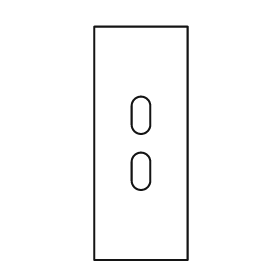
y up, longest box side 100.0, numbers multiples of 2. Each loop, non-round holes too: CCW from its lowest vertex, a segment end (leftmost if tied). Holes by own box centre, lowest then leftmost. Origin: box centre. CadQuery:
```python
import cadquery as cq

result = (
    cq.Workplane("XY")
    .moveTo(-20.0, -50.0)
    .lineTo(20.0, -50.0)
    .lineTo(20.0, 50.0)
    .lineTo(-20.0, 50.0)
    .close()
    .moveTo(-4.0, -16.0)
    .threePointArc((0.0, -20.0), (4.0, -16.0))
    .lineTo(4.0, -8.0)
    .threePointArc((0.0, -4.0), (-4.0, -8.0))
    .close()
    .moveTo(-4.0, 8.0)
    .threePointArc((0.0, 4.0), (4.0, 8.0))
    .lineTo(4.0, 16.0)
    .threePointArc((0.0, 20.0), (-4.0, 16.0))
    .close()
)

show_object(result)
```